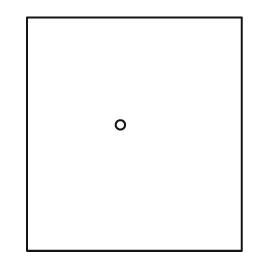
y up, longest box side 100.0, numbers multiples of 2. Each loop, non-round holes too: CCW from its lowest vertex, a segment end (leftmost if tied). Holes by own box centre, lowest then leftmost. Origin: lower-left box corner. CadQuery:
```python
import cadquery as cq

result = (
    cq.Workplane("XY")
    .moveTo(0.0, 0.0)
    .lineTo(92.0, 0.0)
    .lineTo(92.0, 100.0)
    .lineTo(0.0, 100.0)
    .close()
    .moveTo(40.0, 54.0)
    .circle(2.0)
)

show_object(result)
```